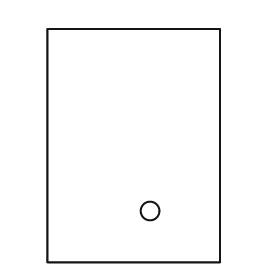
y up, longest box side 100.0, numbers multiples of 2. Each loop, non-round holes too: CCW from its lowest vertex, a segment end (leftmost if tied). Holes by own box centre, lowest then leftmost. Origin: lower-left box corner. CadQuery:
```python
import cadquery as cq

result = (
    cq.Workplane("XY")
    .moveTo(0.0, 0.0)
    .lineTo(74.0, 0.0)
    .lineTo(74.0, 100.0)
    .lineTo(0.0, 100.0)
    .close()
    .moveTo(44.0, 22.0)
    .circle(4.0)
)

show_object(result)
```